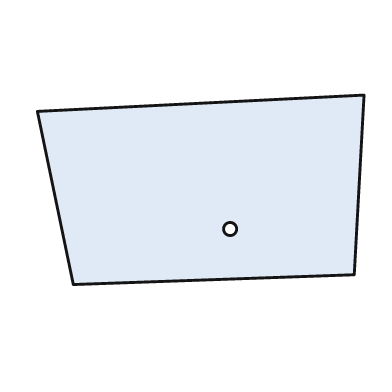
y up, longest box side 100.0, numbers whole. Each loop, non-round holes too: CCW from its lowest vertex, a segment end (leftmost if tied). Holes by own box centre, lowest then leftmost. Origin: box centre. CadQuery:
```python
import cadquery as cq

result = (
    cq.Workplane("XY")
    .moveTo(-39.0, -29.0)
    .lineTo(47.0, -26.0)
    .lineTo(50.0, 29.0)
    .lineTo(-50.0, 24.0)
    .close()
    .moveTo(9.0, -12.0)
    .circle(2.0)
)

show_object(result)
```